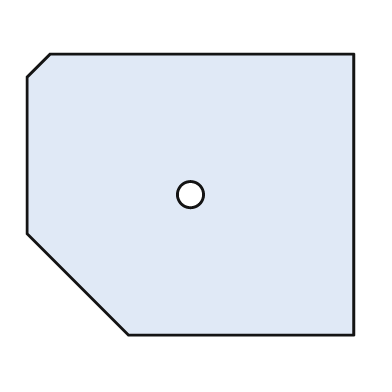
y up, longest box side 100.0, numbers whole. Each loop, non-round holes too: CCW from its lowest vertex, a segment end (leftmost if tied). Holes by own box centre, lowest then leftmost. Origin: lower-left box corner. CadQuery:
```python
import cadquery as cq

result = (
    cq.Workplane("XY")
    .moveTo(31.0, 0.0)
    .lineTo(100.0, 0.0)
    .lineTo(100.0, 86.0)
    .lineTo(7.0, 86.0)
    .lineTo(0.0, 79.0)
    .lineTo(0.0, 31.0)
    .close()
    .moveTo(50.0, 43.0)
    .circle(4.0)
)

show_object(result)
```